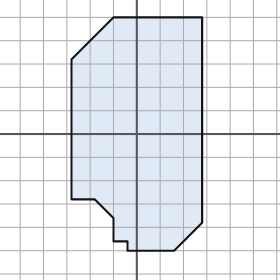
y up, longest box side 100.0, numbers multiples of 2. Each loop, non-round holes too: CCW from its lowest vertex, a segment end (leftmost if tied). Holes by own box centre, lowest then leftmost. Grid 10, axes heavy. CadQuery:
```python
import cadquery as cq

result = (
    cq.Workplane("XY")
    .moveTo(-4.0, -50.0)
    .lineTo(16.0, -50.0)
    .lineTo(28.0, -38.0)
    .lineTo(28.0, 50.0)
    .lineTo(-10.0, 50.0)
    .lineTo(-28.0, 32.0)
    .lineTo(-28.0, -28.0)
    .lineTo(-18.0, -28.0)
    .lineTo(-10.0, -36.0)
    .lineTo(-10.0, -46.0)
    .lineTo(-4.0, -46.0)
    .close()
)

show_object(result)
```